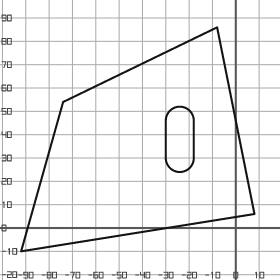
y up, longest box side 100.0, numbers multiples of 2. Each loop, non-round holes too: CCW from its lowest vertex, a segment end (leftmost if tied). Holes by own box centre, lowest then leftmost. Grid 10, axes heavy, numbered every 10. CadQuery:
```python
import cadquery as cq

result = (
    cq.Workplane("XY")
    .moveTo(-92.0, -10.0)
    .lineTo(8.0, 6.0)
    .lineTo(-8.0, 86.0)
    .lineTo(-74.0, 54.0)
    .close()
    .moveTo(-30.0, 30.0)
    .threePointArc((-24.0, 24.0), (-18.0, 30.0))
    .lineTo(-18.0, 46.0)
    .threePointArc((-24.0, 52.0), (-30.0, 46.0))
    .close()
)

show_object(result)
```